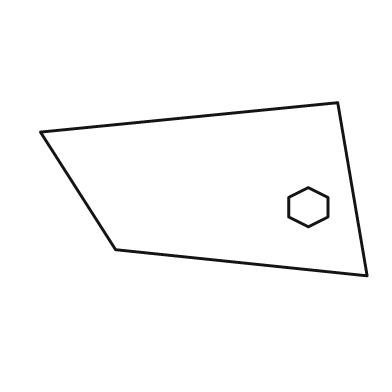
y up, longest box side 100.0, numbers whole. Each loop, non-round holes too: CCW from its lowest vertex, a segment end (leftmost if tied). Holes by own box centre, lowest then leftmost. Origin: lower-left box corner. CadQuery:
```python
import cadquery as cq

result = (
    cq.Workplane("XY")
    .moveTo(100.0, 0.0)
    .lineTo(91.0, 53.0)
    .lineTo(0.0, 44.0)
    .lineTo(23.0, 8.0)
    .close()
    .moveTo(82.0, 15.0)
    .lineTo(88.0, 18.0)
    .lineTo(88.0, 24.0)
    .lineTo(82.0, 27.0)
    .lineTo(76.0, 24.0)
    .lineTo(76.0, 18.0)
    .close()
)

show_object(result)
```